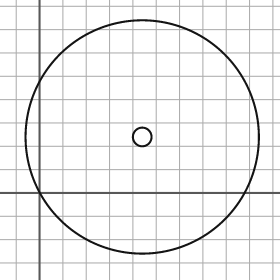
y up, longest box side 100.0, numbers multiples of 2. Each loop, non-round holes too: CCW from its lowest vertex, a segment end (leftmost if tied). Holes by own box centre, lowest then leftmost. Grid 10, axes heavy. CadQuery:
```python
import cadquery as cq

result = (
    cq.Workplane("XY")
    .moveTo(44.0, 24.0)
    .circle(50.0)
    .moveTo(44.0, 24.0)
    .circle(4.0)
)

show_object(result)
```